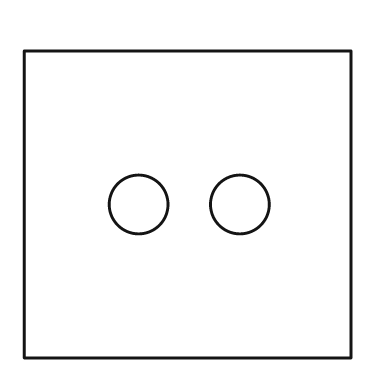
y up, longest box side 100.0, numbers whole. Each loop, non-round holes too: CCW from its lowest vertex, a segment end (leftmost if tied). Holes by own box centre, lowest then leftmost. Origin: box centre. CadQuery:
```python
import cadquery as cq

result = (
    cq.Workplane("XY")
    .moveTo(-50.0, -47.0)
    .lineTo(50.0, -47.0)
    .lineTo(50.0, 47.0)
    .lineTo(-50.0, 47.0)
    .close()
    .moveTo(-15.0, 0.0)
    .circle(9.0)
    .moveTo(16.0, 0.0)
    .circle(9.0)
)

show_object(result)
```